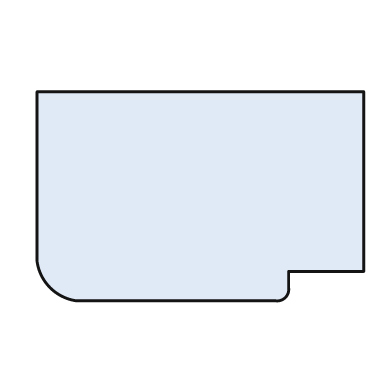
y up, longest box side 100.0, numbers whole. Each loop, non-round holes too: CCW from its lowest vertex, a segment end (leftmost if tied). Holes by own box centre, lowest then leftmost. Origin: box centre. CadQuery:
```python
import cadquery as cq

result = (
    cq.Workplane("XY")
    .moveTo(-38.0, -32.0)
    .lineTo(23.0, -32.0)
    .threePointArc((26.0, -31.0), (27.0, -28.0))
    .lineTo(27.0, -23.0)
    .lineTo(50.0, -23.0)
    .lineTo(50.0, 32.0)
    .lineTo(-50.0, 32.0)
    .lineTo(-50.0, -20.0)
    .threePointArc((-46.0, -28.0), (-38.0, -32.0))
    .close()
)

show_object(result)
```